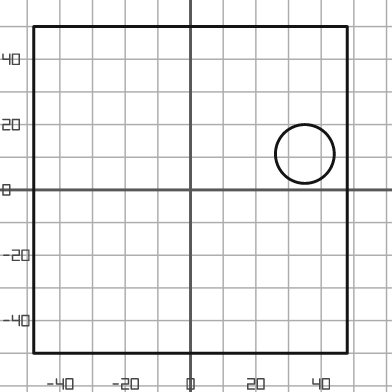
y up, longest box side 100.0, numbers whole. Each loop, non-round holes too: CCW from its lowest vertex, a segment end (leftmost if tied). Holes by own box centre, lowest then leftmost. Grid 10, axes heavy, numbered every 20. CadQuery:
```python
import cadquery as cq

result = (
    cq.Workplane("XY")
    .moveTo(-48.0, -50.0)
    .lineTo(48.0, -50.0)
    .lineTo(48.0, 50.0)
    .lineTo(-48.0, 50.0)
    .close()
    .moveTo(35.0, 11.0)
    .circle(9.0)
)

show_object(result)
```